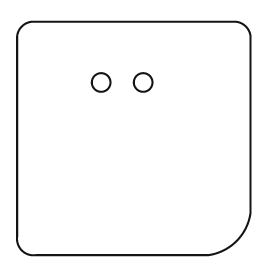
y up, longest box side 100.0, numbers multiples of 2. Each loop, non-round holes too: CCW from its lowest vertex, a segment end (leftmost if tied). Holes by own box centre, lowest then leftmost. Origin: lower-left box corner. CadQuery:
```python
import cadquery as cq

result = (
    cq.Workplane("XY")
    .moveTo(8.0, 0.0)
    .lineTo(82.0, 0.0)
    .threePointArc((94.0, 6.0), (100.0, 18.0))
    .lineTo(100.0, 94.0)
    .threePointArc((98.0, 98.0), (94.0, 100.0))
    .lineTo(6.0, 100.0)
    .threePointArc((2.0, 98.0), (0.0, 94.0))
    .lineTo(0.0, 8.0)
    .threePointArc((2.0, 2.0), (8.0, 0.0))
    .close()
    .moveTo(36.0, 74.0)
    .circle(4.0)
    .moveTo(54.0, 74.0)
    .circle(4.0)
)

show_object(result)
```